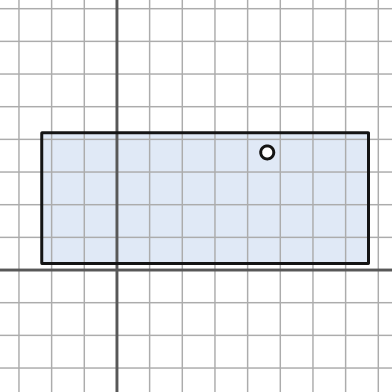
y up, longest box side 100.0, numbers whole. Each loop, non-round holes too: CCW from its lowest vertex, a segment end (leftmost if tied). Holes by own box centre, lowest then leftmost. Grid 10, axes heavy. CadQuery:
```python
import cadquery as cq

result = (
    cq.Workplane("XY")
    .moveTo(-23.0, 2.0)
    .lineTo(77.0, 2.0)
    .lineTo(77.0, 42.0)
    .lineTo(-23.0, 42.0)
    .close()
    .moveTo(46.0, 36.0)
    .circle(2.0)
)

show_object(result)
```